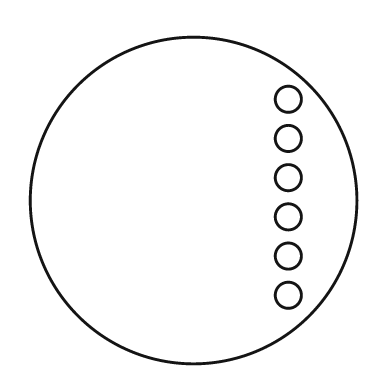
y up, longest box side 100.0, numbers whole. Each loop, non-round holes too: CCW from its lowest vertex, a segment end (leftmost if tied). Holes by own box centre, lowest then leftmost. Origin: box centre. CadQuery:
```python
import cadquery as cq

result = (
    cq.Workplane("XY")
    .moveTo(0.0, 0.0)
    .circle(50.0)
    .moveTo(29.0, -29.0)
    .circle(4.0)
    .moveTo(29.0, -17.0)
    .circle(4.0)
    .moveTo(29.0, -5.0)
    .circle(4.0)
    .moveTo(29.0, 7.0)
    .circle(4.0)
    .moveTo(29.0, 19.0)
    .circle(4.0)
    .moveTo(29.0, 31.0)
    .circle(4.0)
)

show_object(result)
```